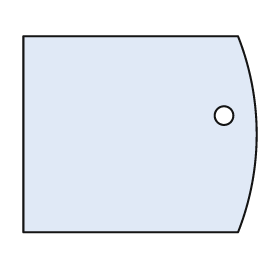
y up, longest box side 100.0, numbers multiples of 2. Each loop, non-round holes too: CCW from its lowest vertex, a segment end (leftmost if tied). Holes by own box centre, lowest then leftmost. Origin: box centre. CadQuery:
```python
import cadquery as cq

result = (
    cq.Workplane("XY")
    .moveTo(-50.0, -42.0)
    .lineTo(42.0, -42.0)
    .threePointArc((50.0, 0.0), (42.0, 42.0))
    .lineTo(-50.0, 42.0)
    .close()
    .moveTo(36.0, 8.0)
    .circle(4.0)
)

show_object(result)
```